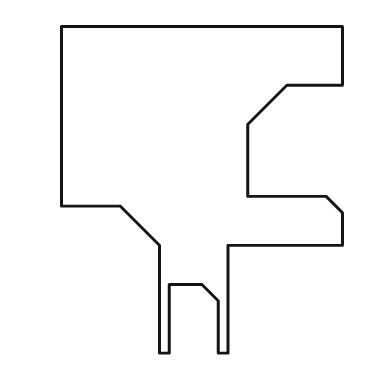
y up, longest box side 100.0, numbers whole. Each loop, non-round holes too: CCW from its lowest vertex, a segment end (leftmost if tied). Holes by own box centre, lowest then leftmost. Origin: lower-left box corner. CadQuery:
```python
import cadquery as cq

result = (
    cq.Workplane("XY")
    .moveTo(30.0, 0.0)
    .lineTo(33.0, 0.0)
    .lineTo(33.0, 21.0)
    .lineTo(43.0, 21.0)
    .lineTo(48.0, 16.0)
    .lineTo(48.0, 0.0)
    .lineTo(51.0, 0.0)
    .lineTo(51.0, 33.0)
    .lineTo(86.0, 33.0)
    .lineTo(86.0, 43.0)
    .lineTo(81.0, 48.0)
    .lineTo(57.0, 48.0)
    .lineTo(57.0, 70.0)
    .lineTo(69.0, 82.0)
    .lineTo(86.0, 82.0)
    .lineTo(86.0, 100.0)
    .lineTo(0.0, 100.0)
    .lineTo(0.0, 45.0)
    .lineTo(18.0, 45.0)
    .lineTo(30.0, 33.0)
    .close()
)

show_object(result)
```